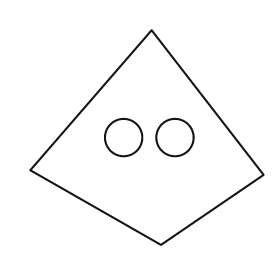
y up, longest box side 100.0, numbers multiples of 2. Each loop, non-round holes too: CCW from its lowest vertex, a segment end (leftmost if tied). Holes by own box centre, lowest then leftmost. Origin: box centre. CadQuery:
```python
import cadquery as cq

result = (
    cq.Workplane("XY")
    .moveTo(6.0, -46.0)
    .lineTo(50.0, -16.0)
    .lineTo(2.0, 46.0)
    .lineTo(-50.0, -14.0)
    .close()
    .moveTo(-10.0, 0.0)
    .circle(8.0)
    .moveTo(12.0, 0.0)
    .circle(8.0)
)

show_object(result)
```